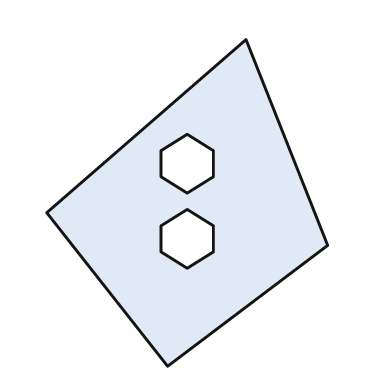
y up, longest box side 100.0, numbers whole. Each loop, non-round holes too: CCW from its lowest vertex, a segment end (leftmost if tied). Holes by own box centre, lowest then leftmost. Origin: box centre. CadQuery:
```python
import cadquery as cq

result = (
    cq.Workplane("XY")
    .moveTo(-6.0, -50.0)
    .lineTo(43.0, -13.0)
    .lineTo(18.0, 50.0)
    .lineTo(-43.0, -3.0)
    .close()
    .moveTo(0.0, -20.0)
    .lineTo(8.0, -15.0)
    .lineTo(8.0, -7.0)
    .lineTo(0.0, -2.0)
    .lineTo(-8.0, -7.0)
    .lineTo(-8.0, -15.0)
    .close()
    .moveTo(0.0, 3.0)
    .lineTo(8.0, 8.0)
    .lineTo(8.0, 16.0)
    .lineTo(0.0, 21.0)
    .lineTo(-8.0, 16.0)
    .lineTo(-8.0, 8.0)
    .close()
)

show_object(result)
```